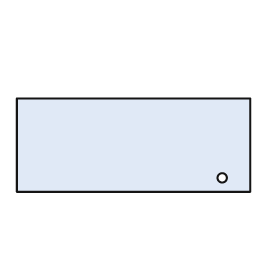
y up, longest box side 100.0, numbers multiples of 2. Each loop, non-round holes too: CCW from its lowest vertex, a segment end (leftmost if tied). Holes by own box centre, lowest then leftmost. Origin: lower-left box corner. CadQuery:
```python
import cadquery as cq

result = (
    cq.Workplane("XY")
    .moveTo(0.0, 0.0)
    .lineTo(100.0, 0.0)
    .lineTo(100.0, 40.0)
    .lineTo(0.0, 40.0)
    .close()
    .moveTo(88.0, 6.0)
    .circle(2.0)
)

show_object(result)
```